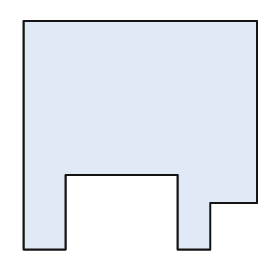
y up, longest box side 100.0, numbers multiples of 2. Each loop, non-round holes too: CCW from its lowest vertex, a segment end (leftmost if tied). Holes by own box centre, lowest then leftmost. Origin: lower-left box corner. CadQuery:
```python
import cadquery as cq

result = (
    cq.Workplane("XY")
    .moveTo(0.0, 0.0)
    .lineTo(18.0, 0.0)
    .lineTo(18.0, 32.0)
    .lineTo(66.0, 32.0)
    .lineTo(66.0, 0.0)
    .lineTo(80.0, 0.0)
    .lineTo(80.0, 20.0)
    .lineTo(100.0, 20.0)
    .lineTo(100.0, 98.0)
    .lineTo(0.0, 98.0)
    .close()
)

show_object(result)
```